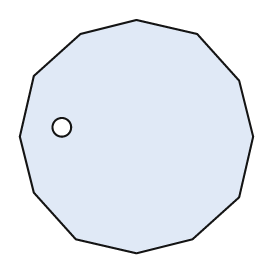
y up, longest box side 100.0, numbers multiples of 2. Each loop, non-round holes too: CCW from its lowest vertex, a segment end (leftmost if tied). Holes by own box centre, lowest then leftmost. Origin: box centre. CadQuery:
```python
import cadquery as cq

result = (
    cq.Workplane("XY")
    .moveTo(0.0, -50.0)
    .lineTo(24.0, -44.0)
    .lineTo(44.0, -26.0)
    .lineTo(50.0, 0.0)
    .lineTo(44.0, 24.0)
    .lineTo(26.0, 44.0)
    .lineTo(0.0, 50.0)
    .lineTo(-24.0, 44.0)
    .lineTo(-44.0, 26.0)
    .lineTo(-50.0, 0.0)
    .lineTo(-44.0, -24.0)
    .lineTo(-26.0, -44.0)
    .close()
    .moveTo(-32.0, 4.0)
    .circle(4.0)
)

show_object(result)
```